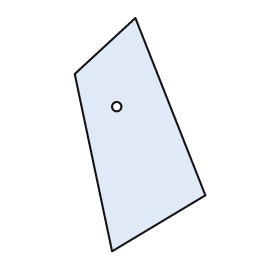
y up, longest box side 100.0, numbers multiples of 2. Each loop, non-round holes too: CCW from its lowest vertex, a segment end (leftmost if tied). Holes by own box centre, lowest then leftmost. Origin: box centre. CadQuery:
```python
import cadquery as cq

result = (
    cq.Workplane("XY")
    .moveTo(-12.0, -50.0)
    .lineTo(28.0, -26.0)
    .lineTo(-2.0, 50.0)
    .lineTo(-28.0, 26.0)
    .close()
    .moveTo(-10.0, 12.0)
    .circle(2.0)
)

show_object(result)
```